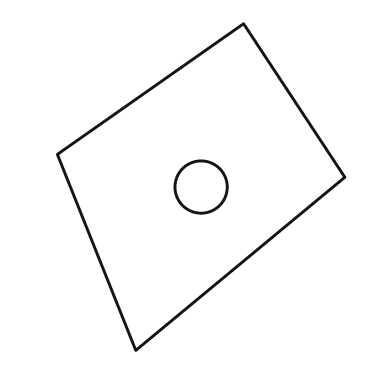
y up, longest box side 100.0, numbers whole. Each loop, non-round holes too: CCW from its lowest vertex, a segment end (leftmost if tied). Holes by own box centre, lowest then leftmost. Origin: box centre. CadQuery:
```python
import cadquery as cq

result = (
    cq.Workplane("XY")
    .moveTo(-20.0, -50.0)
    .lineTo(44.0, 3.0)
    .lineTo(13.0, 50.0)
    .lineTo(-44.0, 10.0)
    .close()
    .moveTo(0.0, 0.0)
    .circle(8.0)
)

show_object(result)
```